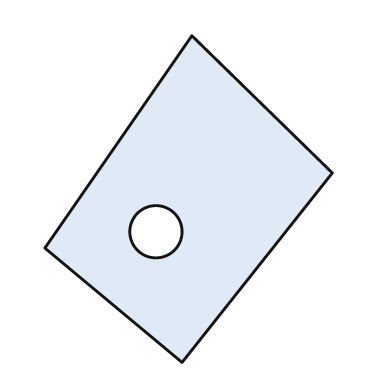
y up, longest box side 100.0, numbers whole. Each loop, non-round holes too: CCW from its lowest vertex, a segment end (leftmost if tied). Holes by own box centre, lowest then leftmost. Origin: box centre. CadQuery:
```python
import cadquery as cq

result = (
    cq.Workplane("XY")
    .moveTo(-2.0, -50.0)
    .lineTo(44.0, 8.0)
    .lineTo(1.0, 50.0)
    .lineTo(-44.0, -15.0)
    .close()
    .moveTo(-10.0, -10.0)
    .circle(8.0)
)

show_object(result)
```